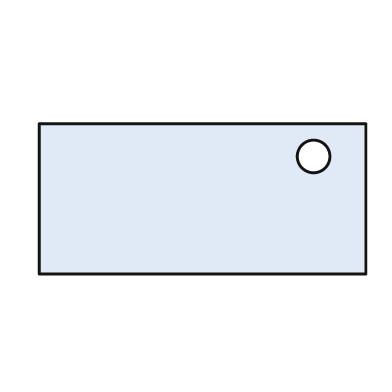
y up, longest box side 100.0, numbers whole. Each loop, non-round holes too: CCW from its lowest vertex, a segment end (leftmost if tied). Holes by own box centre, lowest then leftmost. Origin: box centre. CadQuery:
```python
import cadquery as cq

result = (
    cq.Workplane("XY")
    .moveTo(-50.0, -23.0)
    .lineTo(50.0, -23.0)
    .lineTo(50.0, 23.0)
    .lineTo(-50.0, 23.0)
    .close()
    .moveTo(34.0, 13.0)
    .circle(5.0)
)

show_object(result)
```